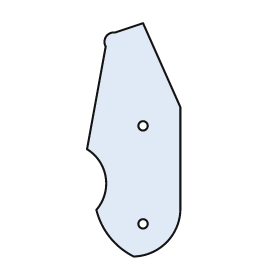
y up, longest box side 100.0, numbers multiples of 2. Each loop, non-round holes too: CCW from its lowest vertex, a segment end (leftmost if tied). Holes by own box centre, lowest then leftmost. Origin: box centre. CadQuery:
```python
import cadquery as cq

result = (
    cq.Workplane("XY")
    .moveTo(0.0, -50.0)
    .threePointArc((14.0, -44.0), (20.0, -30.0))
    .lineTo(20.0, 14.0)
    .lineTo(4.0, 50.0)
    .lineTo(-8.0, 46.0)
    .threePointArc((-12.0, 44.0), (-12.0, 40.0))
    .lineTo(-20.0, -4.0)
    .threePointArc((-12.0, -16.0), (-16.0, -30.0))
    .threePointArc((-10.0, -42.0), (0.0, -50.0))
    .close()
    .moveTo(4.0, -36.0)
    .circle(2.0)
    .moveTo(4.0, 6.0)
    .circle(2.0)
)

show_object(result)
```